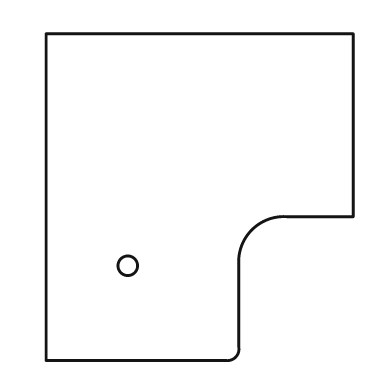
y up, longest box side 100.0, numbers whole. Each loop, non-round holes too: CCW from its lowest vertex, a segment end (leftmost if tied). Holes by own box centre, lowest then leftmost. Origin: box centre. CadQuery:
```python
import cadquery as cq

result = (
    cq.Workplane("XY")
    .moveTo(-47.0, -50.0)
    .lineTo(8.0, -50.0)
    .threePointArc((11.0, -49.0), (12.0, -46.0))
    .lineTo(12.0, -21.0)
    .threePointArc((16.0, -10.0), (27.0, -6.0))
    .lineTo(47.0, -6.0)
    .lineTo(47.0, 50.0)
    .lineTo(-47.0, 50.0)
    .close()
    .moveTo(-22.0, -21.0)
    .circle(3.0)
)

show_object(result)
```